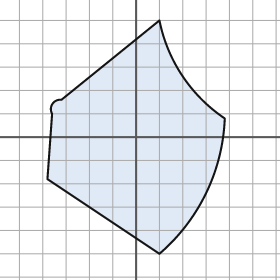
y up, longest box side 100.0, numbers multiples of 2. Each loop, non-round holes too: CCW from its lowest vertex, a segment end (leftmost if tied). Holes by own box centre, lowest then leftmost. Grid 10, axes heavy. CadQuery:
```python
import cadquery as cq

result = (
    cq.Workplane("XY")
    .moveTo(10.0, -50.0)
    .threePointArc((30.0, -24.0), (38.0, 8.0))
    .threePointArc((20.0, 26.0), (10.0, 50.0))
    .lineTo(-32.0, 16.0)
    .threePointArc((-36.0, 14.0), (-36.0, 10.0))
    .lineTo(-38.0, -18.0)
    .close()
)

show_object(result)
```